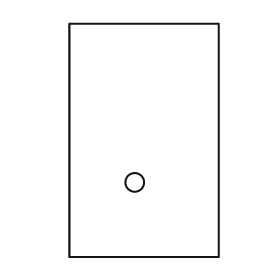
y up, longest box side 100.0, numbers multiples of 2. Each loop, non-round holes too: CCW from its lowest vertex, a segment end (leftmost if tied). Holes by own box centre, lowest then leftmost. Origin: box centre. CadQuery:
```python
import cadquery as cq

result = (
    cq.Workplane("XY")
    .moveTo(-32.0, -50.0)
    .lineTo(32.0, -50.0)
    .lineTo(32.0, 50.0)
    .lineTo(-32.0, 50.0)
    .close()
    .moveTo(-4.0, -18.0)
    .circle(4.0)
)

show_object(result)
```